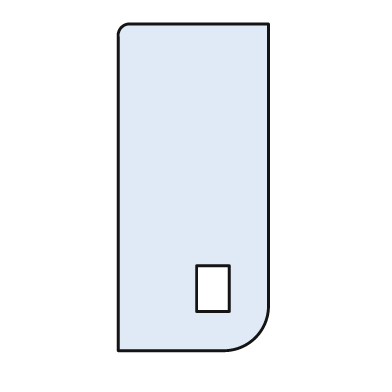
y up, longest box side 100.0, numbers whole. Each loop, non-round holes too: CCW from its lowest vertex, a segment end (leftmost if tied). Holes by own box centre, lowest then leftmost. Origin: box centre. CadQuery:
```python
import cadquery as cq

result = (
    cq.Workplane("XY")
    .moveTo(-23.0, -50.0)
    .lineTo(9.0, -50.0)
    .threePointArc((19.0, -46.0), (23.0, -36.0))
    .lineTo(23.0, 50.0)
    .lineTo(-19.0, 50.0)
    .threePointArc((-22.0, 49.0), (-23.0, 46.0))
    .close()
    .moveTo(1.0, -38.0)
    .lineTo(11.0, -38.0)
    .lineTo(11.0, -24.0)
    .lineTo(1.0, -24.0)
    .close()
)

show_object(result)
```